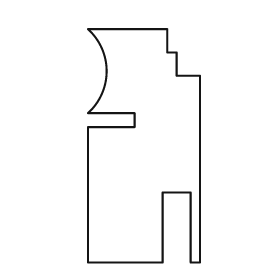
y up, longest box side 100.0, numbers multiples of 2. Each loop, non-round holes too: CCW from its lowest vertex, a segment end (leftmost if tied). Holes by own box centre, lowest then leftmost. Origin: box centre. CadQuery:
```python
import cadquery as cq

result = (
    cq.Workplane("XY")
    .moveTo(-24.0, -50.0)
    .lineTo(8.0, -50.0)
    .lineTo(8.0, -20.0)
    .lineTo(20.0, -20.0)
    .lineTo(20.0, -50.0)
    .lineTo(24.0, -50.0)
    .lineTo(24.0, 30.0)
    .lineTo(14.0, 30.0)
    .lineTo(14.0, 40.0)
    .lineTo(10.0, 40.0)
    .lineTo(10.0, 50.0)
    .lineTo(-24.0, 50.0)
    .threePointArc((-16.0, 32.0), (-24.0, 14.0))
    .lineTo(-4.0, 14.0)
    .lineTo(-4.0, 8.0)
    .lineTo(-24.0, 8.0)
    .close()
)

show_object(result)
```